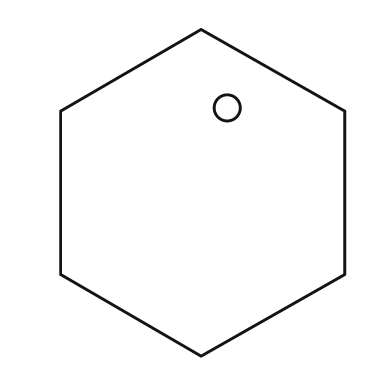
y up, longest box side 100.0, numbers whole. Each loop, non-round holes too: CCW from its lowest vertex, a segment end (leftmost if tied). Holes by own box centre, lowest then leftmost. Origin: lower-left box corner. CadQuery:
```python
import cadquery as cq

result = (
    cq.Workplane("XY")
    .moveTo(43.0, 0.0)
    .lineTo(87.0, 25.0)
    .lineTo(87.0, 75.0)
    .lineTo(43.0, 100.0)
    .lineTo(0.0, 75.0)
    .lineTo(0.0, 25.0)
    .close()
    .moveTo(51.0, 76.0)
    .circle(4.0)
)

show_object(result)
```